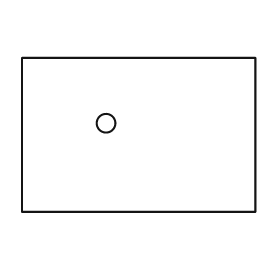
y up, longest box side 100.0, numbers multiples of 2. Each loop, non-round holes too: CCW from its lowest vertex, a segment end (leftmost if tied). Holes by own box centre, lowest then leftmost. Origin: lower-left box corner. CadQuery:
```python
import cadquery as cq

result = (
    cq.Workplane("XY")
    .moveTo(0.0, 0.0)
    .lineTo(100.0, 0.0)
    .lineTo(100.0, 66.0)
    .lineTo(0.0, 66.0)
    .close()
    .moveTo(36.0, 38.0)
    .circle(4.0)
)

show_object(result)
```